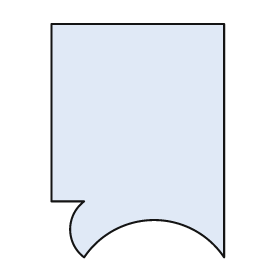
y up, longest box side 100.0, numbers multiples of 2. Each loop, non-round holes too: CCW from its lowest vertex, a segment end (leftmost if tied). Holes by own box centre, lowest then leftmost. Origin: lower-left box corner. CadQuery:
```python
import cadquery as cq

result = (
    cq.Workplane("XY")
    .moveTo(14.0, 0.0)
    .threePointArc((44.0, 16.0), (74.0, 0.0))
    .lineTo(74.0, 100.0)
    .lineTo(0.0, 100.0)
    .lineTo(0.0, 24.0)
    .lineTo(14.0, 24.0)
    .threePointArc((8.0, 12.0), (14.0, 0.0))
    .close()
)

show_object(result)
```